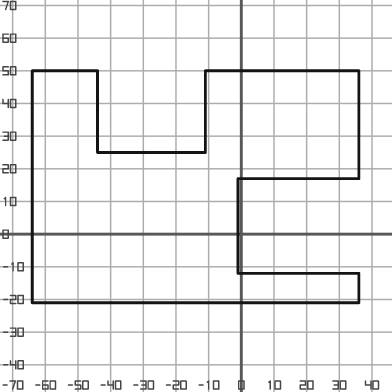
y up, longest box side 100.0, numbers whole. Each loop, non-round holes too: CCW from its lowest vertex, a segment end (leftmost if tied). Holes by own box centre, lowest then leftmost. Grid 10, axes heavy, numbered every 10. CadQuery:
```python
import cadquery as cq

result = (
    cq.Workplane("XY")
    .moveTo(-64.0, -21.0)
    .lineTo(36.0, -21.0)
    .lineTo(36.0, -12.0)
    .lineTo(-1.0, -12.0)
    .lineTo(-1.0, 17.0)
    .lineTo(36.0, 17.0)
    .lineTo(36.0, 50.0)
    .lineTo(-11.0, 50.0)
    .lineTo(-11.0, 25.0)
    .lineTo(-44.0, 25.0)
    .lineTo(-44.0, 50.0)
    .lineTo(-64.0, 50.0)
    .close()
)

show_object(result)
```